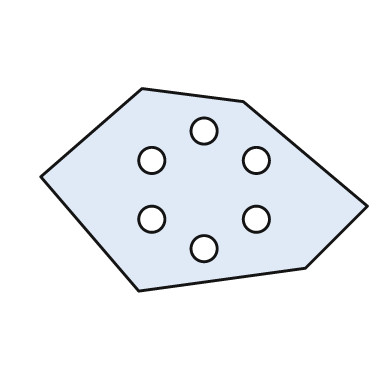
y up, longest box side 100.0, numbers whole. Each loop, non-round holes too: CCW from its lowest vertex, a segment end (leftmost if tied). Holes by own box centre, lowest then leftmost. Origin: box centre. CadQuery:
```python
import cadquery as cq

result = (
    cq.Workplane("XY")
    .moveTo(-20.0, -31.0)
    .lineTo(31.0, -24.0)
    .lineTo(50.0, -5.0)
    .lineTo(12.0, 27.0)
    .lineTo(-19.0, 31.0)
    .lineTo(-50.0, 4.0)
    .close()
    .moveTo(0.0, -18.0)
    .circle(4.0)
    .moveTo(-16.0, -9.0)
    .circle(4.0)
    .moveTo(16.0, -9.0)
    .circle(4.0)
    .moveTo(-16.0, 9.0)
    .circle(4.0)
    .moveTo(16.0, 9.0)
    .circle(4.0)
    .moveTo(0.0, 18.0)
    .circle(4.0)
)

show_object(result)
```